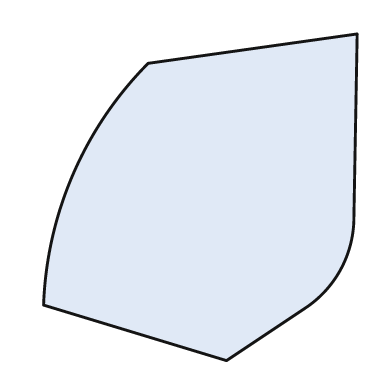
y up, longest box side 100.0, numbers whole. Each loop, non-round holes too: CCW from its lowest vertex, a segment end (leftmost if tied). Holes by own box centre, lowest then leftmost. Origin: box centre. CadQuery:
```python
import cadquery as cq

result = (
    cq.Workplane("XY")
    .moveTo(8.0, -50.0)
    .lineTo(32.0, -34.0)
    .threePointArc((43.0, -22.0), (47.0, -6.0))
    .lineTo(48.0, 50.0)
    .lineTo(-16.0, 41.0)
    .threePointArc((-39.0, 7.0), (-48.0, -33.0))
    .close()
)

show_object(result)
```